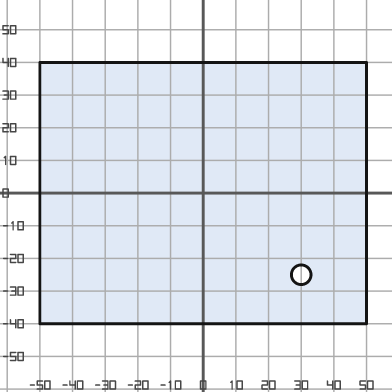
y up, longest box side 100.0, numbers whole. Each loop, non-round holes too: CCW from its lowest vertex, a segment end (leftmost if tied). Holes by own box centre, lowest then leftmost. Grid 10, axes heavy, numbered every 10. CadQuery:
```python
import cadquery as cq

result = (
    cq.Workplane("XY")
    .moveTo(-50.0, -40.0)
    .lineTo(50.0, -40.0)
    .lineTo(50.0, 40.0)
    .lineTo(-50.0, 40.0)
    .close()
    .moveTo(30.0, -25.0)
    .circle(3.0)
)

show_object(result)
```